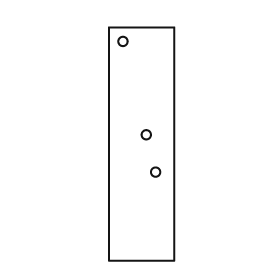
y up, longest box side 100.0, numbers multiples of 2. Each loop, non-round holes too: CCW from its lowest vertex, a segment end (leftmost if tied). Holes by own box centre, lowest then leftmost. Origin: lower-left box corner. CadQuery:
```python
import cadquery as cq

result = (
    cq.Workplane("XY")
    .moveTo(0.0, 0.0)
    .lineTo(28.0, 0.0)
    .lineTo(28.0, 100.0)
    .lineTo(0.0, 100.0)
    .close()
    .moveTo(20.0, 38.0)
    .circle(2.0)
    .moveTo(16.0, 54.0)
    .circle(2.0)
    .moveTo(6.0, 94.0)
    .circle(2.0)
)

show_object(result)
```